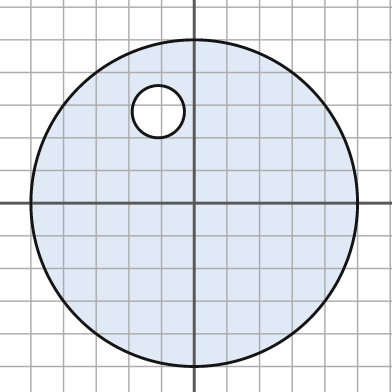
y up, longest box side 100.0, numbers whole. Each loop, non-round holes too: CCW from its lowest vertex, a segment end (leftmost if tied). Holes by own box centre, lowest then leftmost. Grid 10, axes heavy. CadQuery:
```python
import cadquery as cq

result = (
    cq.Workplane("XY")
    .moveTo(0.0, 0.0)
    .circle(50.0)
    .moveTo(-11.0, 28.0)
    .circle(8.0)
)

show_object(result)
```